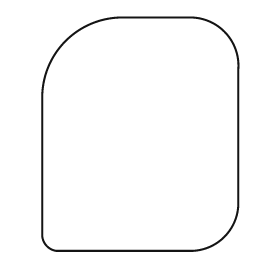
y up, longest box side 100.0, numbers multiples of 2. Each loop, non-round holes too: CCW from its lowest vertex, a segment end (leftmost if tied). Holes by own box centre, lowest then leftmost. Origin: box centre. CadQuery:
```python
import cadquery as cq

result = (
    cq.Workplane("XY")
    .moveTo(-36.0, -50.0)
    .lineTo(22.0, -50.0)
    .threePointArc((36.0, -44.0), (42.0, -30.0))
    .lineTo(42.0, 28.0)
    .threePointArc((36.0, 44.0), (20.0, 50.0))
    .lineTo(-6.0, 50.0)
    .threePointArc((-32.0, 40.0), (-42.0, 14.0))
    .lineTo(-42.0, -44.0)
    .threePointArc((-40.0, -48.0), (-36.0, -50.0))
    .close()
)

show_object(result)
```